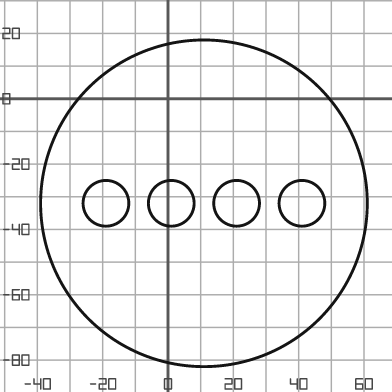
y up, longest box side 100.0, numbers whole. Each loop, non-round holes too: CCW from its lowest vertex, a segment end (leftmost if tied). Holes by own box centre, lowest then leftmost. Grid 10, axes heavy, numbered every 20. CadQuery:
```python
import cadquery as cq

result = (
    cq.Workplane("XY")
    .moveTo(11.0, -32.0)
    .circle(50.0)
    .moveTo(-19.0, -32.0)
    .circle(7.0)
    .moveTo(1.0, -32.0)
    .circle(7.0)
    .moveTo(21.0, -32.0)
    .circle(7.0)
    .moveTo(41.0, -32.0)
    .circle(7.0)
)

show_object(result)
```